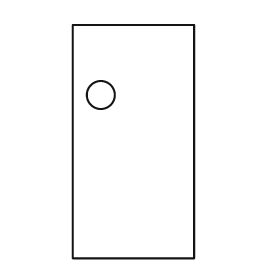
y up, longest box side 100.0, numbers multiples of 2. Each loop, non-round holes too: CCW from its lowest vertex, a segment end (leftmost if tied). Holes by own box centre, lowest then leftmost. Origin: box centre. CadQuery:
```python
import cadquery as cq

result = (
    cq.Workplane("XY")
    .moveTo(-26.0, -50.0)
    .lineTo(26.0, -50.0)
    .lineTo(26.0, 50.0)
    .lineTo(-26.0, 50.0)
    .close()
    .moveTo(-14.0, 20.0)
    .circle(6.0)
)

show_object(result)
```